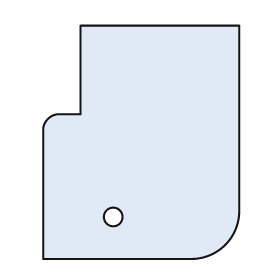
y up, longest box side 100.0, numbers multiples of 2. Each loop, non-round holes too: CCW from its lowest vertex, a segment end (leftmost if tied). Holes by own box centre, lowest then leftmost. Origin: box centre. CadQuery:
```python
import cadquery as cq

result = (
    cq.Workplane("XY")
    .moveTo(-42.0, -50.0)
    .lineTo(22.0, -50.0)
    .threePointArc((36.0, -44.0), (42.0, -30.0))
    .lineTo(42.0, 50.0)
    .lineTo(-26.0, 50.0)
    .lineTo(-26.0, 12.0)
    .lineTo(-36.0, 12.0)
    .threePointArc((-40.0, 10.0), (-42.0, 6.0))
    .close()
    .moveTo(-12.0, -32.0)
    .circle(4.0)
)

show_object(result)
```